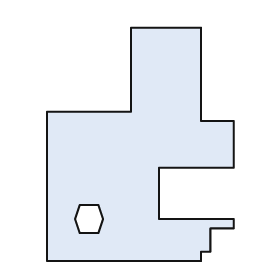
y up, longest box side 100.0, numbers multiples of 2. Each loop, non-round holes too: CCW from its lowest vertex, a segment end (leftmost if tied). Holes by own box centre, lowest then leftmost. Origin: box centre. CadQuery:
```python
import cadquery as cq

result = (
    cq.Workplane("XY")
    .moveTo(-40.0, -50.0)
    .lineTo(26.0, -50.0)
    .lineTo(26.0, -46.0)
    .lineTo(30.0, -46.0)
    .lineTo(30.0, -36.0)
    .lineTo(40.0, -36.0)
    .lineTo(40.0, -32.0)
    .lineTo(8.0, -32.0)
    .lineTo(8.0, -10.0)
    .lineTo(40.0, -10.0)
    .lineTo(40.0, 10.0)
    .lineTo(26.0, 10.0)
    .lineTo(26.0, 50.0)
    .lineTo(-4.0, 50.0)
    .lineTo(-4.0, 14.0)
    .lineTo(-40.0, 14.0)
    .close()
    .moveTo(-26.0, -38.0)
    .lineTo(-18.0, -38.0)
    .lineTo(-16.0, -32.0)
    .lineTo(-18.0, -26.0)
    .lineTo(-26.0, -26.0)
    .lineTo(-28.0, -32.0)
    .close()
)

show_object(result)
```